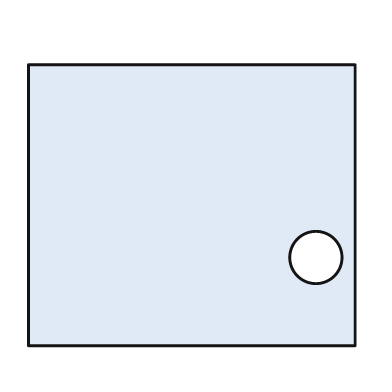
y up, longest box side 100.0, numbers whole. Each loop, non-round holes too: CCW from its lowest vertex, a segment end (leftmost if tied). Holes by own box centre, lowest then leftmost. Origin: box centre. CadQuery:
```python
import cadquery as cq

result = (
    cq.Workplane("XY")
    .moveTo(-50.0, -43.0)
    .lineTo(50.0, -43.0)
    .lineTo(50.0, 43.0)
    .lineTo(-50.0, 43.0)
    .close()
    .moveTo(38.0, -16.0)
    .circle(8.0)
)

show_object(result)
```